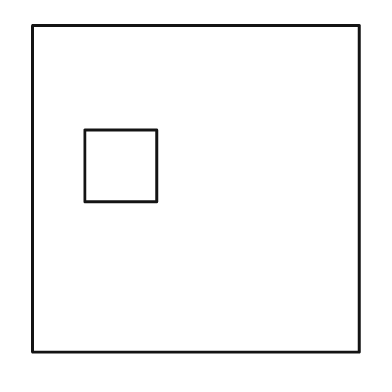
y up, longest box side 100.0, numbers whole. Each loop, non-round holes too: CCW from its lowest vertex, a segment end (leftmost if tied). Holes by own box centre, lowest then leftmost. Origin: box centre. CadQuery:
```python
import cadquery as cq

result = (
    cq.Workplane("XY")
    .moveTo(-50.0, -50.0)
    .lineTo(50.0, -50.0)
    .lineTo(50.0, 50.0)
    .lineTo(-50.0, 50.0)
    .close()
    .moveTo(-34.0, -4.0)
    .lineTo(-12.0, -4.0)
    .lineTo(-12.0, 18.0)
    .lineTo(-34.0, 18.0)
    .close()
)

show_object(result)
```